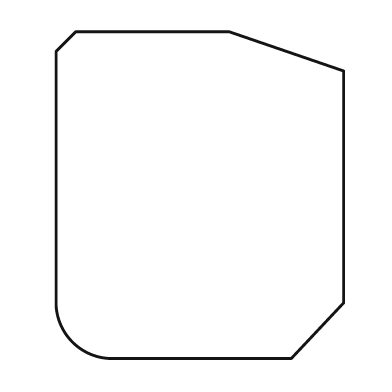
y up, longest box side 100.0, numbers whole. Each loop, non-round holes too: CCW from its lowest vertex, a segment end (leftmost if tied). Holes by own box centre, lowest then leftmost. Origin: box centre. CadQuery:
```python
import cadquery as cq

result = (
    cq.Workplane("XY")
    .moveTo(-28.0, -50.0)
    .lineTo(28.0, -50.0)
    .lineTo(44.0, -33.0)
    .lineTo(44.0, 38.0)
    .lineTo(9.0, 50.0)
    .lineTo(-38.0, 50.0)
    .lineTo(-44.0, 44.0)
    .lineTo(-44.0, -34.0)
    .threePointArc((-39.0, -45.0), (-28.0, -50.0))
    .close()
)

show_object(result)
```